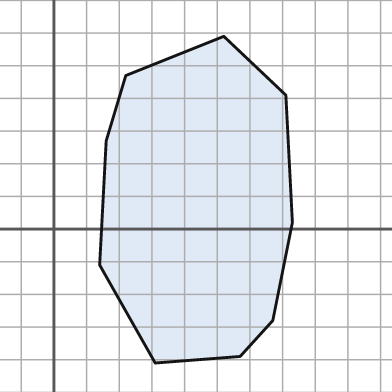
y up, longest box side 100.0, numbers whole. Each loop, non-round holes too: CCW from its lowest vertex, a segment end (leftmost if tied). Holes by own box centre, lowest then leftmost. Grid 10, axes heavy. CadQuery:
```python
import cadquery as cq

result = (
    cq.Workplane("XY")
    .moveTo(31.0, -41.0)
    .lineTo(57.0, -39.0)
    .lineTo(67.0, -28.0)
    .lineTo(73.0, 2.0)
    .lineTo(71.0, 41.0)
    .lineTo(52.0, 59.0)
    .lineTo(22.0, 47.0)
    .lineTo(16.0, 27.0)
    .lineTo(14.0, -11.0)
    .close()
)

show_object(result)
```